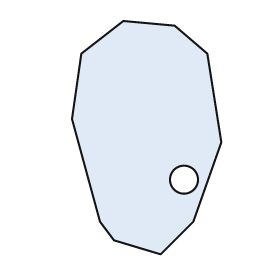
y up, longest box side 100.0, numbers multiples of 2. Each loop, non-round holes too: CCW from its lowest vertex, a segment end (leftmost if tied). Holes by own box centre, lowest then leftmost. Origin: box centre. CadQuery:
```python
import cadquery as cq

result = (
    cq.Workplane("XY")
    .moveTo(6.0, -50.0)
    .lineTo(20.0, -36.0)
    .lineTo(32.0, -2.0)
    .lineTo(26.0, 36.0)
    .lineTo(12.0, 48.0)
    .lineTo(-10.0, 50.0)
    .lineTo(-28.0, 36.0)
    .lineTo(-32.0, 8.0)
    .lineTo(-20.0, -36.0)
    .lineTo(-14.0, -44.0)
    .close()
    .moveTo(16.0, -18.0)
    .circle(6.0)
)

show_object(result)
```